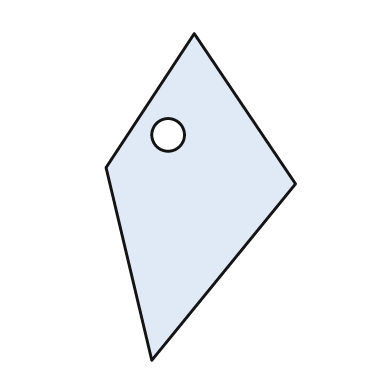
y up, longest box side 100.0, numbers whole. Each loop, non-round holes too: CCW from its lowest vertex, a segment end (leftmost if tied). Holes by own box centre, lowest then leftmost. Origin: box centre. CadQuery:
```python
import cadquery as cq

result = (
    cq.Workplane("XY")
    .moveTo(-15.0, -50.0)
    .lineTo(29.0, 4.0)
    .lineTo(-2.0, 50.0)
    .lineTo(-29.0, 9.0)
    .close()
    .moveTo(-10.0, 19.0)
    .circle(5.0)
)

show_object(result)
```